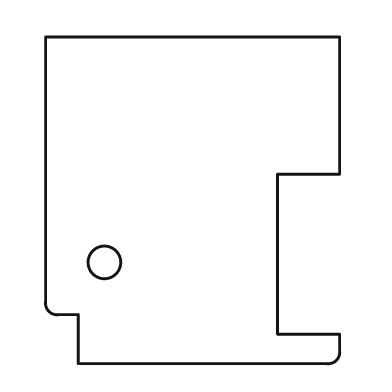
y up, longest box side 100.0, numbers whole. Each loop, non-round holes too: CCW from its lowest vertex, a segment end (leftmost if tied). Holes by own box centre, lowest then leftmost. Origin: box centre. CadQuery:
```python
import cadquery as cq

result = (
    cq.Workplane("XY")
    .moveTo(-35.0, -50.0)
    .lineTo(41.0, -50.0)
    .threePointArc((44.0, -49.0), (45.0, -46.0))
    .lineTo(45.0, -41.0)
    .lineTo(26.0, -41.0)
    .lineTo(26.0, 8.0)
    .lineTo(45.0, 8.0)
    .lineTo(45.0, 50.0)
    .lineTo(-45.0, 50.0)
    .lineTo(-45.0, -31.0)
    .threePointArc((-44.0, -34.0), (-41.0, -35.0))
    .lineTo(-35.0, -35.0)
    .close()
    .moveTo(-27.0, -19.0)
    .circle(5.0)
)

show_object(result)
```